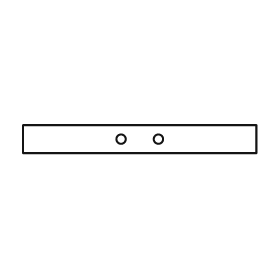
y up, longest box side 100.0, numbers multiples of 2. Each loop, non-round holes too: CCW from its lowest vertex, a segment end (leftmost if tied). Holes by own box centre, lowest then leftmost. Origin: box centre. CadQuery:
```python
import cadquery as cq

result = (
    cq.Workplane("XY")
    .moveTo(-50.0, -6.0)
    .lineTo(50.0, -6.0)
    .lineTo(50.0, 6.0)
    .lineTo(-50.0, 6.0)
    .close()
    .moveTo(-8.0, 0.0)
    .circle(2.0)
    .moveTo(8.0, 0.0)
    .circle(2.0)
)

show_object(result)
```